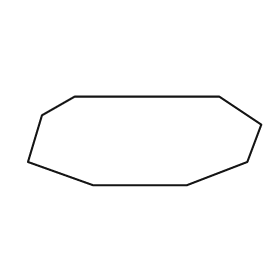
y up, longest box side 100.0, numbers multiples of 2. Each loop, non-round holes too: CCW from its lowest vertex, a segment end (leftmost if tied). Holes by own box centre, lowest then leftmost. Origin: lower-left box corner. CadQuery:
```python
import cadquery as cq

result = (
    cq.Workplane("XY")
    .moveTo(28.0, 0.0)
    .lineTo(68.0, 0.0)
    .lineTo(94.0, 10.0)
    .lineTo(100.0, 26.0)
    .lineTo(82.0, 38.0)
    .lineTo(20.0, 38.0)
    .lineTo(6.0, 30.0)
    .lineTo(0.0, 10.0)
    .close()
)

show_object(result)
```